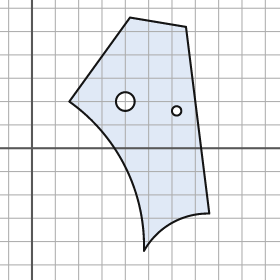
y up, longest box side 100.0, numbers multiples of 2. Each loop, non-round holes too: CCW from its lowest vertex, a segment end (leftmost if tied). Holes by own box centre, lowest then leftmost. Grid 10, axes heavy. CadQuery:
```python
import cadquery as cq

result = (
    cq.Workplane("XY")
    .moveTo(48.0, -44.0)
    .threePointArc((60.0, -32.0), (76.0, -28.0))
    .lineTo(66.0, 52.0)
    .lineTo(42.0, 56.0)
    .lineTo(16.0, 20.0)
    .threePointArc((40.0, -8.0), (48.0, -44.0))
    .close()
    .moveTo(62.0, 16.0)
    .circle(2.0)
    .moveTo(40.0, 20.0)
    .circle(4.0)
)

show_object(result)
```